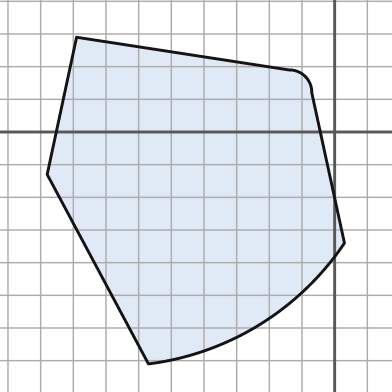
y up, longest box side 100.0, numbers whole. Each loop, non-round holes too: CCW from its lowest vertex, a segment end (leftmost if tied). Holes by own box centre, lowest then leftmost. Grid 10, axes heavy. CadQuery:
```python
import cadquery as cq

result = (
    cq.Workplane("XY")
    .moveTo(-57.0, -71.0)
    .threePointArc((-23.0, -59.0), (3.0, -34.0))
    .lineTo(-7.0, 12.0)
    .threePointArc((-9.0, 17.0), (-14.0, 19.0))
    .lineTo(-79.0, 29.0)
    .lineTo(-88.0, -13.0)
    .close()
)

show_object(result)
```